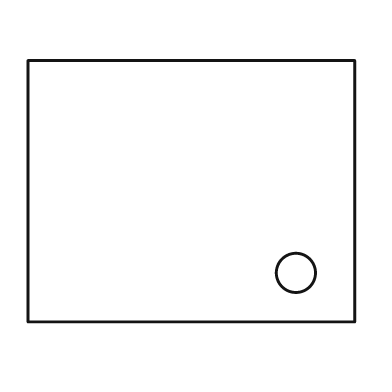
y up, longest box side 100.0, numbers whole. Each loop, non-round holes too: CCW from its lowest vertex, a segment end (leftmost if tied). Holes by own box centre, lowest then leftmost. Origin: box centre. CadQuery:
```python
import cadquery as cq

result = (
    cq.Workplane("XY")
    .moveTo(-50.0, -40.0)
    .lineTo(50.0, -40.0)
    .lineTo(50.0, 40.0)
    .lineTo(-50.0, 40.0)
    .close()
    .moveTo(32.0, -25.0)
    .circle(6.0)
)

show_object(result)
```